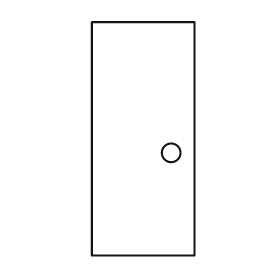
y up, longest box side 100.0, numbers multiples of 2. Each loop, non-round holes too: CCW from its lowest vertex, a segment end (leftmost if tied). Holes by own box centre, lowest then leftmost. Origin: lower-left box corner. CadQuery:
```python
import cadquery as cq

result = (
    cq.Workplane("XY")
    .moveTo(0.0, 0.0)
    .lineTo(44.0, 0.0)
    .lineTo(44.0, 100.0)
    .lineTo(0.0, 100.0)
    .close()
    .moveTo(34.0, 44.0)
    .circle(4.0)
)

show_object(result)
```